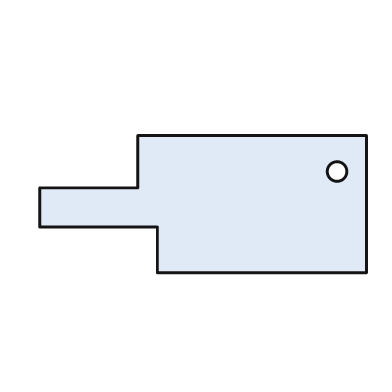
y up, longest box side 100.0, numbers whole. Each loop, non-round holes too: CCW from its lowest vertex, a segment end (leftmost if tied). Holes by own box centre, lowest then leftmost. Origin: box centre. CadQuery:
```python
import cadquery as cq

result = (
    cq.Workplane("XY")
    .moveTo(-14.0, -21.0)
    .lineTo(50.0, -21.0)
    .lineTo(50.0, 21.0)
    .lineTo(-20.0, 21.0)
    .lineTo(-20.0, 5.0)
    .lineTo(-50.0, 5.0)
    .lineTo(-50.0, -7.0)
    .lineTo(-14.0, -7.0)
    .close()
    .moveTo(41.0, 10.0)
    .circle(3.0)
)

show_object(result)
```